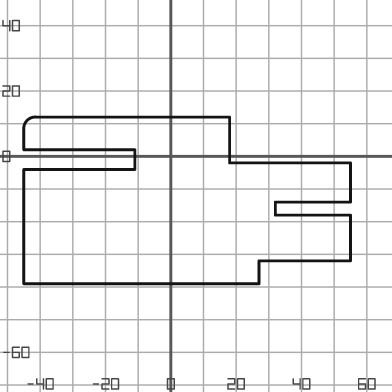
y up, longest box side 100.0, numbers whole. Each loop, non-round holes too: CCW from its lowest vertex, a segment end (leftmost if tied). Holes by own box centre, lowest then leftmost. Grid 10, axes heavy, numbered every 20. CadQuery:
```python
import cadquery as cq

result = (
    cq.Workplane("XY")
    .moveTo(-45.0, -39.0)
    .lineTo(27.0, -39.0)
    .lineTo(27.0, -32.0)
    .lineTo(55.0, -32.0)
    .lineTo(55.0, -18.0)
    .lineTo(32.0, -18.0)
    .lineTo(32.0, -14.0)
    .lineTo(55.0, -14.0)
    .lineTo(55.0, -2.0)
    .lineTo(18.0, -2.0)
    .lineTo(18.0, 12.0)
    .lineTo(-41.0, 12.0)
    .threePointArc((-44.0, 11.0), (-45.0, 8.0))
    .lineTo(-45.0, 2.0)
    .lineTo(-11.0, 2.0)
    .lineTo(-11.0, -4.0)
    .lineTo(-45.0, -4.0)
    .close()
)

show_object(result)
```